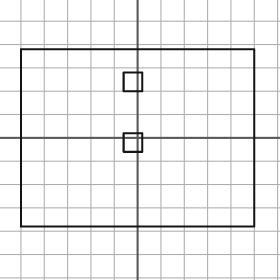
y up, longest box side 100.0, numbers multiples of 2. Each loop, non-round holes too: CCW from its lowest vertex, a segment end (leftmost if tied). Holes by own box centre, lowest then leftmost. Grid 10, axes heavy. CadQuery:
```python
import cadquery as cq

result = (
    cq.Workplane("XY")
    .moveTo(-50.0, -38.0)
    .lineTo(50.0, -38.0)
    .lineTo(50.0, 38.0)
    .lineTo(-50.0, 38.0)
    .close()
    .moveTo(-6.0, -6.0)
    .lineTo(2.0, -6.0)
    .lineTo(2.0, 2.0)
    .lineTo(-6.0, 2.0)
    .close()
    .moveTo(-6.0, 20.0)
    .lineTo(2.0, 20.0)
    .lineTo(2.0, 28.0)
    .lineTo(-6.0, 28.0)
    .close()
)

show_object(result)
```